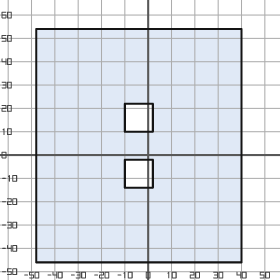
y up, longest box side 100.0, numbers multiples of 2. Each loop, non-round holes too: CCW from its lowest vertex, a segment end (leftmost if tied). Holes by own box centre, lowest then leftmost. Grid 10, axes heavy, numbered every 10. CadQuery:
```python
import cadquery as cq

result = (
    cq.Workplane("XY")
    .moveTo(-48.0, -46.0)
    .lineTo(40.0, -46.0)
    .lineTo(40.0, 54.0)
    .lineTo(-48.0, 54.0)
    .close()
    .moveTo(-10.0, -14.0)
    .lineTo(2.0, -14.0)
    .lineTo(2.0, -2.0)
    .lineTo(-10.0, -2.0)
    .close()
    .moveTo(-10.0, 10.0)
    .lineTo(2.0, 10.0)
    .lineTo(2.0, 22.0)
    .lineTo(-10.0, 22.0)
    .close()
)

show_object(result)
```